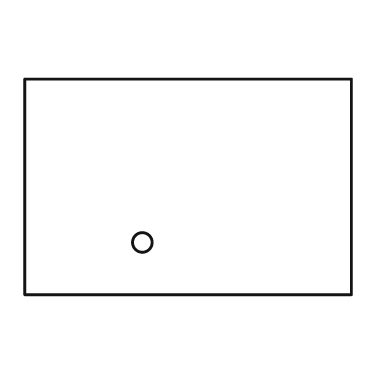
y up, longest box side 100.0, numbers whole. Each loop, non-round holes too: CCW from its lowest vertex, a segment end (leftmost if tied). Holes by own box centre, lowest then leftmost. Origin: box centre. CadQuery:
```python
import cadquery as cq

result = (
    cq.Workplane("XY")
    .moveTo(-50.0, -33.0)
    .lineTo(50.0, -33.0)
    .lineTo(50.0, 33.0)
    .lineTo(-50.0, 33.0)
    .close()
    .moveTo(-14.0, -17.0)
    .circle(3.0)
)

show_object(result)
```